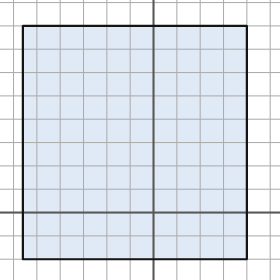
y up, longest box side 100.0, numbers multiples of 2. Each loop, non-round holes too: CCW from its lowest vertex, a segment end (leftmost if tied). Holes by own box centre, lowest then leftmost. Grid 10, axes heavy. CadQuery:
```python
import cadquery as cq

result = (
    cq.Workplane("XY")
    .moveTo(-56.0, -20.0)
    .lineTo(40.0, -20.0)
    .lineTo(40.0, 80.0)
    .lineTo(-56.0, 80.0)
    .close()
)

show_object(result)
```